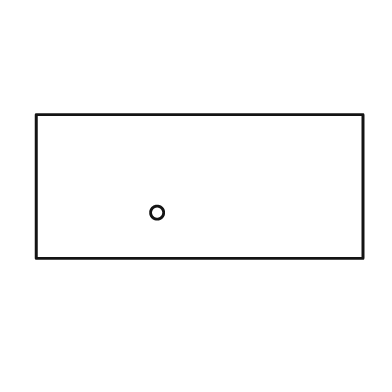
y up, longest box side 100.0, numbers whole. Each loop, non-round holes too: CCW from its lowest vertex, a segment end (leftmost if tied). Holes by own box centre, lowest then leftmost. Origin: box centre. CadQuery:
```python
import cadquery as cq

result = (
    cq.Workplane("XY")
    .moveTo(-50.0, -22.0)
    .lineTo(50.0, -22.0)
    .lineTo(50.0, 22.0)
    .lineTo(-50.0, 22.0)
    .close()
    .moveTo(-13.0, -8.0)
    .circle(2.0)
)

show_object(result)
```